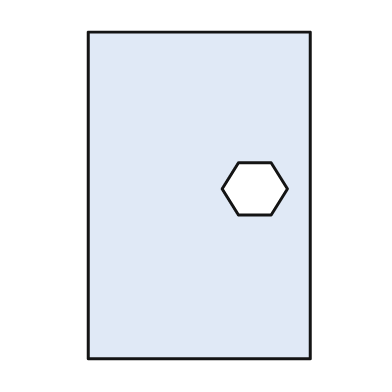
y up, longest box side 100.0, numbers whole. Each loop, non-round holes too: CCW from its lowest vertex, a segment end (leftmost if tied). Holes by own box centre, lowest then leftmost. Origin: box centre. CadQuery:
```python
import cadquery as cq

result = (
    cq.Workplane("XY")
    .moveTo(-34.0, -50.0)
    .lineTo(34.0, -50.0)
    .lineTo(34.0, 50.0)
    .lineTo(-34.0, 50.0)
    .close()
    .moveTo(12.0, -6.0)
    .lineTo(22.0, -6.0)
    .lineTo(27.0, 2.0)
    .lineTo(22.0, 10.0)
    .lineTo(12.0, 10.0)
    .lineTo(7.0, 2.0)
    .close()
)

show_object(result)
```